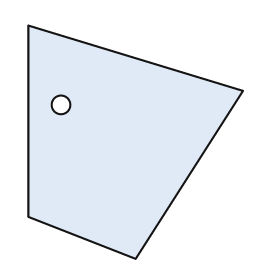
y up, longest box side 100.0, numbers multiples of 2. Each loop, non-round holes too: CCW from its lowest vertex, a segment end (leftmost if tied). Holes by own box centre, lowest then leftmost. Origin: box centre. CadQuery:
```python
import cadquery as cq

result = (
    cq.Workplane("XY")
    .moveTo(0.0, -50.0)
    .lineTo(46.0, 22.0)
    .lineTo(-46.0, 50.0)
    .lineTo(-46.0, -32.0)
    .close()
    .moveTo(-32.0, 16.0)
    .circle(4.0)
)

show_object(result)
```